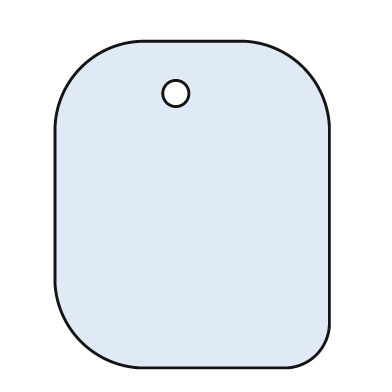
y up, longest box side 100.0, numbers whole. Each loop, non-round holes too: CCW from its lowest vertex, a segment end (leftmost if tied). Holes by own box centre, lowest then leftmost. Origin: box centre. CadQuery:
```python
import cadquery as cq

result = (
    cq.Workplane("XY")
    .moveTo(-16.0, -50.0)
    .lineTo(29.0, -50.0)
    .threePointArc((38.0, -46.0), (42.0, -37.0))
    .lineTo(42.0, 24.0)
    .threePointArc((34.0, 42.0), (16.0, 50.0))
    .lineTo(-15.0, 50.0)
    .threePointArc((-34.0, 42.0), (-42.0, 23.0))
    .lineTo(-42.0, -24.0)
    .threePointArc((-34.0, -42.0), (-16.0, -50.0))
    .close()
    .moveTo(-5.0, 34.0)
    .circle(4.0)
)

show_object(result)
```